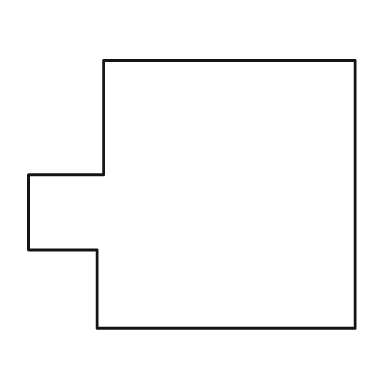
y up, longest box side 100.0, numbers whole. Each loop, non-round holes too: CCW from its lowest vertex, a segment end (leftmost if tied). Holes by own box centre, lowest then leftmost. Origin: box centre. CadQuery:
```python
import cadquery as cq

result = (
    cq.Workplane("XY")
    .moveTo(-29.0, -41.0)
    .lineTo(50.0, -41.0)
    .lineTo(50.0, 41.0)
    .lineTo(-27.0, 41.0)
    .lineTo(-27.0, 6.0)
    .lineTo(-50.0, 6.0)
    .lineTo(-50.0, -17.0)
    .lineTo(-29.0, -17.0)
    .close()
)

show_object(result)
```